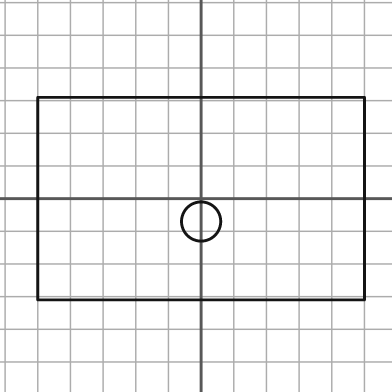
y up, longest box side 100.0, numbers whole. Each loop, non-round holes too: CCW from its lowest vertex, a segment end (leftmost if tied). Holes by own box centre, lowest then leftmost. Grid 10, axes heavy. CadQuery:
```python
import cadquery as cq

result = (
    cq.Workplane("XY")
    .moveTo(-50.0, -31.0)
    .lineTo(50.0, -31.0)
    .lineTo(50.0, 31.0)
    .lineTo(-50.0, 31.0)
    .close()
    .moveTo(0.0, -7.0)
    .circle(6.0)
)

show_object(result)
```